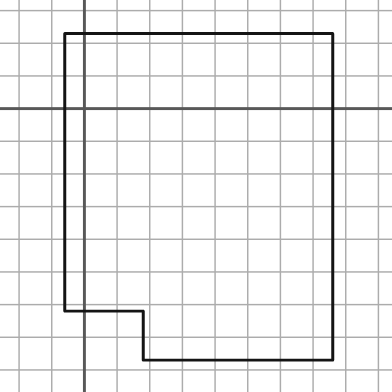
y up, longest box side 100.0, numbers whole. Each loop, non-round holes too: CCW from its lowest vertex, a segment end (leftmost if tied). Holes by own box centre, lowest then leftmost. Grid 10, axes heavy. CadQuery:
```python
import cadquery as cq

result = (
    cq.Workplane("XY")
    .moveTo(18.0, -77.0)
    .lineTo(76.0, -77.0)
    .lineTo(76.0, 23.0)
    .lineTo(-6.0, 23.0)
    .lineTo(-6.0, -62.0)
    .lineTo(18.0, -62.0)
    .close()
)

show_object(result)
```